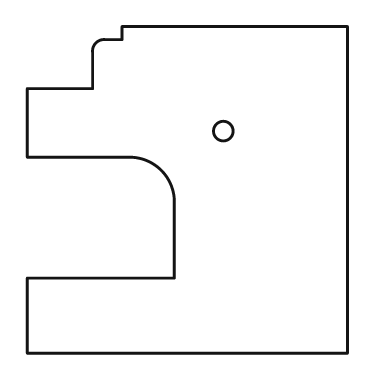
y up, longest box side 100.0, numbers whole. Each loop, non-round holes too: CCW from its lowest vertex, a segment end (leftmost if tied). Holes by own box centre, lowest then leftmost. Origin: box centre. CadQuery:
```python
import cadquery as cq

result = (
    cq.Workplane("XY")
    .moveTo(-49.0, -50.0)
    .lineTo(49.0, -50.0)
    .lineTo(49.0, 50.0)
    .lineTo(-20.0, 50.0)
    .lineTo(-20.0, 46.0)
    .lineTo(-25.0, 46.0)
    .threePointArc((-28.0, 45.0), (-29.0, 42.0))
    .lineTo(-29.0, 31.0)
    .lineTo(-49.0, 31.0)
    .lineTo(-49.0, 10.0)
    .lineTo(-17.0, 10.0)
    .threePointArc((-8.0, 6.0), (-4.0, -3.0))
    .lineTo(-4.0, -27.0)
    .lineTo(-49.0, -27.0)
    .close()
    .moveTo(11.0, 18.0)
    .circle(3.0)
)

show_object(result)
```